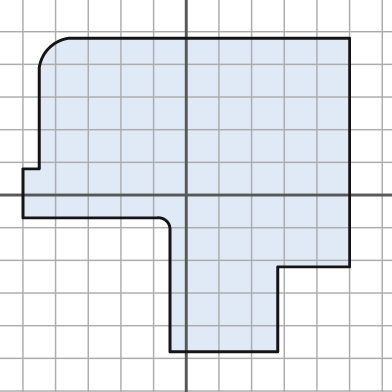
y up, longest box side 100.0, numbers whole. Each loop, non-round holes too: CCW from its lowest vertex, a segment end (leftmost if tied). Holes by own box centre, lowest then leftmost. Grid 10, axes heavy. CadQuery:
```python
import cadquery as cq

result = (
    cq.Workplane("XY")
    .moveTo(-5.0, -48.0)
    .lineTo(28.0, -48.0)
    .lineTo(28.0, -22.0)
    .lineTo(50.0, -22.0)
    .lineTo(50.0, 48.0)
    .lineTo(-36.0, 48.0)
    .threePointArc((-42.0, 45.0), (-45.0, 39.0))
    .lineTo(-45.0, 8.0)
    .lineTo(-50.0, 8.0)
    .lineTo(-50.0, -7.0)
    .lineTo(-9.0, -7.0)
    .threePointArc((-6.0, -8.0), (-5.0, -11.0))
    .close()
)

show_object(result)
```